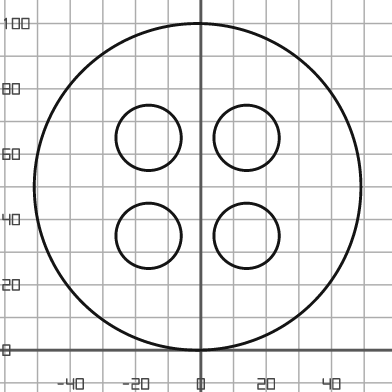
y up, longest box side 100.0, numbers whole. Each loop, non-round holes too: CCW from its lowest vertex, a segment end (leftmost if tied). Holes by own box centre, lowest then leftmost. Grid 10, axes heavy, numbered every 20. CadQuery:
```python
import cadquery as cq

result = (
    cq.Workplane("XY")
    .moveTo(-1.0, 50.0)
    .circle(50.0)
    .moveTo(-16.0, 35.0)
    .circle(10.0)
    .moveTo(14.0, 35.0)
    .circle(10.0)
    .moveTo(-16.0, 65.0)
    .circle(10.0)
    .moveTo(14.0, 65.0)
    .circle(10.0)
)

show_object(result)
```